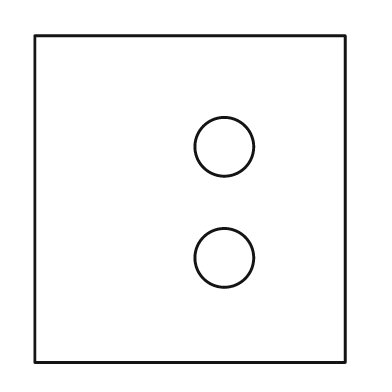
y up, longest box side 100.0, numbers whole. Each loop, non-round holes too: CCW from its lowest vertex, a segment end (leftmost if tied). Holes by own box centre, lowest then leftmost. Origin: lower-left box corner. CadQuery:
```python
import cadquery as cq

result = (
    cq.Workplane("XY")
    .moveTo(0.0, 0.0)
    .lineTo(95.0, 0.0)
    .lineTo(95.0, 100.0)
    .lineTo(0.0, 100.0)
    .close()
    .moveTo(58.0, 32.0)
    .circle(9.0)
    .moveTo(58.0, 66.0)
    .circle(9.0)
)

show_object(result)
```